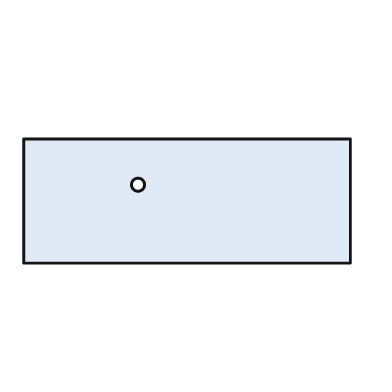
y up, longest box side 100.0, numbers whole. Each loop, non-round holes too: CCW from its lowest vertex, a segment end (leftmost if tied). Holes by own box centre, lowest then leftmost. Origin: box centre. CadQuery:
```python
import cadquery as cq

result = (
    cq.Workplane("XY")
    .moveTo(-50.0, -19.0)
    .lineTo(50.0, -19.0)
    .lineTo(50.0, 19.0)
    .lineTo(-50.0, 19.0)
    .close()
    .moveTo(-15.0, 5.0)
    .circle(2.0)
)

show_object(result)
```